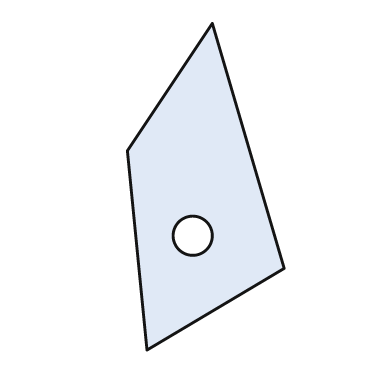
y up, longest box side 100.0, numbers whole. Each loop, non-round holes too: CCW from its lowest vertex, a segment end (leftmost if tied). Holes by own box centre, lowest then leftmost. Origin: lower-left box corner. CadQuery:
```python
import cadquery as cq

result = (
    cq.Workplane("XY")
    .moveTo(6.0, 0.0)
    .lineTo(48.0, 25.0)
    .lineTo(26.0, 100.0)
    .lineTo(0.0, 61.0)
    .close()
    .moveTo(20.0, 35.0)
    .circle(6.0)
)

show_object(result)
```